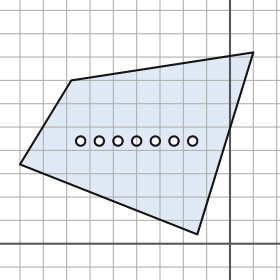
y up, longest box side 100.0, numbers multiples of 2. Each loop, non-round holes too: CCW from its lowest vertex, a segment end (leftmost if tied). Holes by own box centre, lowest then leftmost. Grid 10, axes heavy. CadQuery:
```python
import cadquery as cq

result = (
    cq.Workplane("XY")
    .moveTo(-14.0, 4.0)
    .lineTo(10.0, 82.0)
    .lineTo(-68.0, 70.0)
    .lineTo(-90.0, 34.0)
    .close()
    .moveTo(-64.0, 44.0)
    .circle(2.0)
    .moveTo(-56.0, 44.0)
    .circle(2.0)
    .moveTo(-48.0, 44.0)
    .circle(2.0)
    .moveTo(-40.0, 44.0)
    .circle(2.0)
    .moveTo(-32.0, 44.0)
    .circle(2.0)
    .moveTo(-24.0, 44.0)
    .circle(2.0)
    .moveTo(-16.0, 44.0)
    .circle(2.0)
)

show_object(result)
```